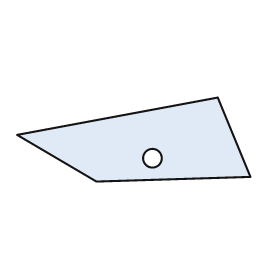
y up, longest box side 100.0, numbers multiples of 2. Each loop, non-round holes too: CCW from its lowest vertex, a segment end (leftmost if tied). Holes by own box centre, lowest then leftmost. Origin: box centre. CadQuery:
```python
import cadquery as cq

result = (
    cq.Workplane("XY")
    .moveTo(-16.0, -18.0)
    .lineTo(50.0, -16.0)
    .lineTo(36.0, 18.0)
    .lineTo(-50.0, 2.0)
    .close()
    .moveTo(8.0, -8.0)
    .circle(4.0)
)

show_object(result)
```